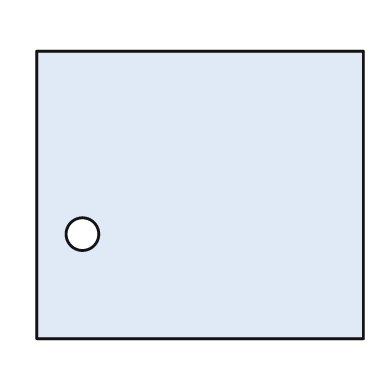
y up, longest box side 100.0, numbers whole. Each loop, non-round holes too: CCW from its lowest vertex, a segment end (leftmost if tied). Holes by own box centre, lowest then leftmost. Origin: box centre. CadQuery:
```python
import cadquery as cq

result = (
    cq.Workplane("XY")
    .moveTo(-50.0, -44.0)
    .lineTo(50.0, -44.0)
    .lineTo(50.0, 44.0)
    .lineTo(-50.0, 44.0)
    .close()
    .moveTo(-36.0, -12.0)
    .circle(5.0)
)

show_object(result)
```